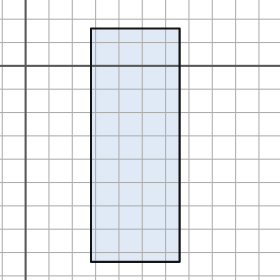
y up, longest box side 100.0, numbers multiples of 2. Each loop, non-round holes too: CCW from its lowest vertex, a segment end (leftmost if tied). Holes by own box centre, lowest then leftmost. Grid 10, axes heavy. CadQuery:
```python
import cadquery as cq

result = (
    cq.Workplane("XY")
    .moveTo(28.0, -84.0)
    .lineTo(66.0, -84.0)
    .lineTo(66.0, 16.0)
    .lineTo(28.0, 16.0)
    .close()
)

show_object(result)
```